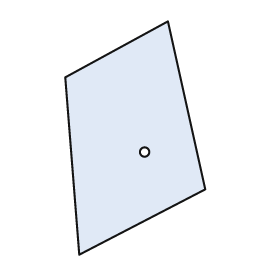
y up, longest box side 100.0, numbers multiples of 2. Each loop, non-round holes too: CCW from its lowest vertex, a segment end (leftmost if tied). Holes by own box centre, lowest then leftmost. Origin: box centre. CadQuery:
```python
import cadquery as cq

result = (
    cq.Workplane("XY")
    .moveTo(-24.0, -50.0)
    .lineTo(30.0, -22.0)
    .lineTo(14.0, 50.0)
    .lineTo(-30.0, 26.0)
    .close()
    .moveTo(4.0, -6.0)
    .circle(2.0)
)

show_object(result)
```